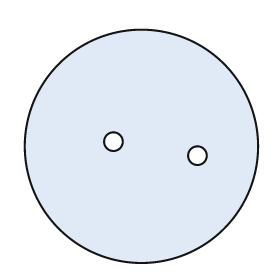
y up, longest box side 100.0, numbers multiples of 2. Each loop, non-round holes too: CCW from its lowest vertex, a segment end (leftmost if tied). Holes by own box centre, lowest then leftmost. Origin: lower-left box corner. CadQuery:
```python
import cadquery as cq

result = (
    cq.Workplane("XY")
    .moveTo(50.0, 50.0)
    .circle(50.0)
    .moveTo(74.0, 46.0)
    .circle(4.0)
    .moveTo(38.0, 52.0)
    .circle(4.0)
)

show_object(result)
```